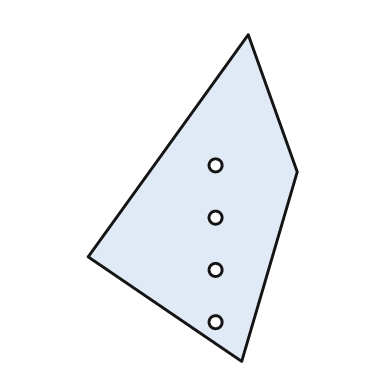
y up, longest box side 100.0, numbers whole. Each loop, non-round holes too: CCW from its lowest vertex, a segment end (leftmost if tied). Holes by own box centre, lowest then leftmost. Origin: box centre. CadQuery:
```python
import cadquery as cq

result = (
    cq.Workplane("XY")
    .moveTo(15.0, -50.0)
    .lineTo(32.0, 8.0)
    .lineTo(17.0, 50.0)
    .lineTo(-32.0, -18.0)
    .close()
    .moveTo(7.0, -38.0)
    .circle(2.0)
    .moveTo(7.0, -22.0)
    .circle(2.0)
    .moveTo(7.0, -6.0)
    .circle(2.0)
    .moveTo(7.0, 10.0)
    .circle(2.0)
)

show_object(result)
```